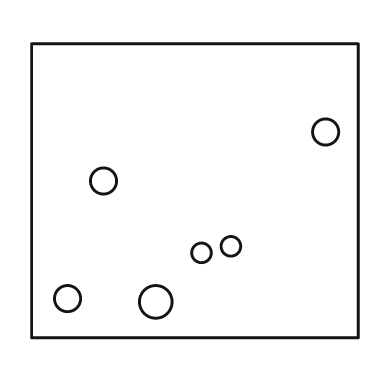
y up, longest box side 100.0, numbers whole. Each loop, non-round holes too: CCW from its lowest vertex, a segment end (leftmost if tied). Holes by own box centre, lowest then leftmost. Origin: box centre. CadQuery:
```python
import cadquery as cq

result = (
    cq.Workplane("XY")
    .moveTo(-50.0, -45.0)
    .lineTo(50.0, -45.0)
    .lineTo(50.0, 45.0)
    .lineTo(-50.0, 45.0)
    .close()
    .moveTo(-12.0, -34.0)
    .circle(5.0)
    .moveTo(-39.0, -33.0)
    .circle(4.0)
    .moveTo(2.0, -19.0)
    .circle(3.0)
    .moveTo(11.0, -17.0)
    .circle(3.0)
    .moveTo(-28.0, 3.0)
    .circle(4.0)
    .moveTo(40.0, 18.0)
    .circle(4.0)
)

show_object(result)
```